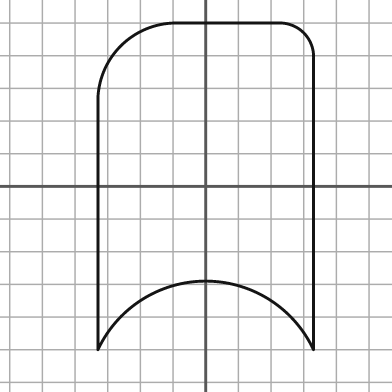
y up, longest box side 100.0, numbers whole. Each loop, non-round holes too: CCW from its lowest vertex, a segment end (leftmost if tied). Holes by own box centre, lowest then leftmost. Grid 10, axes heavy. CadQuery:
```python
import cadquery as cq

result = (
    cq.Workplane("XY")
    .moveTo(-33.0, -50.0)
    .threePointArc((0.0, -29.0), (33.0, -50.0))
    .lineTo(33.0, 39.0)
    .threePointArc((30.0, 47.0), (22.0, 50.0))
    .lineTo(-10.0, 50.0)
    .threePointArc((-26.0, 43.0), (-33.0, 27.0))
    .close()
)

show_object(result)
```